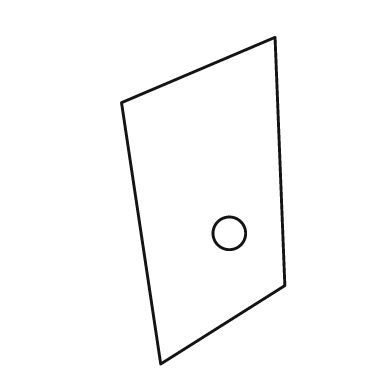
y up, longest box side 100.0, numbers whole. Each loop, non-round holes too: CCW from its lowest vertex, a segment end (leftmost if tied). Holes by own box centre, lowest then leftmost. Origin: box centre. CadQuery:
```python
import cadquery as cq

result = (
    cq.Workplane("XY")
    .moveTo(-13.0, -50.0)
    .lineTo(25.0, -26.0)
    .lineTo(22.0, 50.0)
    .lineTo(-25.0, 30.0)
    .close()
    .moveTo(8.0, -10.0)
    .circle(5.0)
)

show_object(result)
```